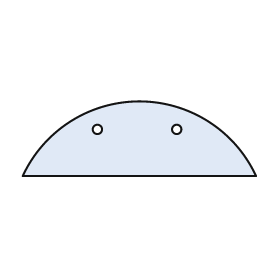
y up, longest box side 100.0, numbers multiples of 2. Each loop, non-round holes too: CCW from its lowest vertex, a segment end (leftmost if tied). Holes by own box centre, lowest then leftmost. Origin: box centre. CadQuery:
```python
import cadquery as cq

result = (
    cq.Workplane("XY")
    .moveTo(-50.0, -16.0)
    .lineTo(50.0, -16.0)
    .threePointArc((0.0, 16.0), (-50.0, -16.0))
    .close()
    .moveTo(-18.0, 4.0)
    .circle(2.0)
    .moveTo(16.0, 4.0)
    .circle(2.0)
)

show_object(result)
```